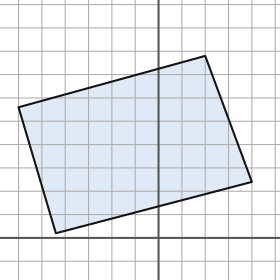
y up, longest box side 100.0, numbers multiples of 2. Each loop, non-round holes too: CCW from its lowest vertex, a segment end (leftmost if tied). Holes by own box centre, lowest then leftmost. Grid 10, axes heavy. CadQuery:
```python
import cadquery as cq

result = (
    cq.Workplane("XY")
    .moveTo(-44.0, 2.0)
    .lineTo(40.0, 24.0)
    .lineTo(20.0, 78.0)
    .lineTo(-60.0, 56.0)
    .close()
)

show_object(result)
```